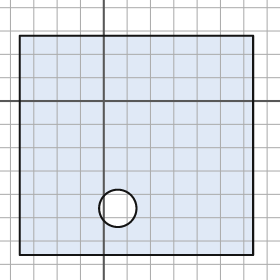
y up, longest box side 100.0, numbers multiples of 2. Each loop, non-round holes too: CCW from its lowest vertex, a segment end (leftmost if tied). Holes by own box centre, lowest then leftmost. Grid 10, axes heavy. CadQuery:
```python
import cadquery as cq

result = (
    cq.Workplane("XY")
    .moveTo(-36.0, -66.0)
    .lineTo(64.0, -66.0)
    .lineTo(64.0, 28.0)
    .lineTo(-36.0, 28.0)
    .close()
    .moveTo(6.0, -46.0)
    .circle(8.0)
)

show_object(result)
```